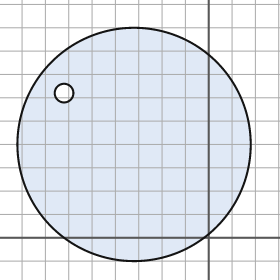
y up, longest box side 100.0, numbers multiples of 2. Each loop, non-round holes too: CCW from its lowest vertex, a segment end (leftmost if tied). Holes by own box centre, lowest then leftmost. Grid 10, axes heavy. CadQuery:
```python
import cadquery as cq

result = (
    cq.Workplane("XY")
    .moveTo(-32.0, 40.0)
    .circle(50.0)
    .moveTo(-62.0, 62.0)
    .circle(4.0)
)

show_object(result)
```